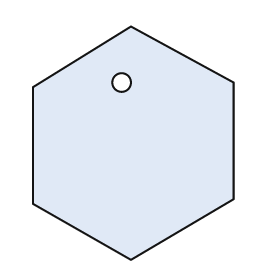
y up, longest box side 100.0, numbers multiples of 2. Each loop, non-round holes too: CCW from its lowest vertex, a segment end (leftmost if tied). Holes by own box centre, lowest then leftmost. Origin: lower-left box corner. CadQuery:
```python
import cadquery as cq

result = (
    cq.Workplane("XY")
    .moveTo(42.0, 0.0)
    .lineTo(86.0, 26.0)
    .lineTo(86.0, 76.0)
    .lineTo(42.0, 100.0)
    .lineTo(0.0, 74.0)
    .lineTo(0.0, 24.0)
    .close()
    .moveTo(38.0, 76.0)
    .circle(4.0)
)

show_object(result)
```